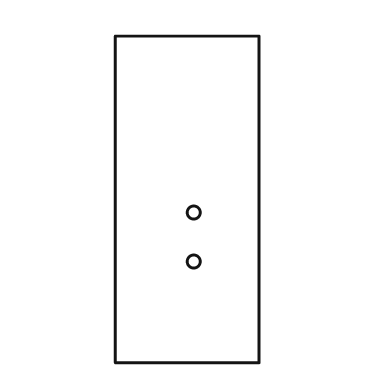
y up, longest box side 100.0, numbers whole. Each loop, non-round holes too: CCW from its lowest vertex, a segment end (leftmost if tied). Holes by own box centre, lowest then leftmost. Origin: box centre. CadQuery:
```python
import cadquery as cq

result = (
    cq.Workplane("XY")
    .moveTo(-22.0, -50.0)
    .lineTo(22.0, -50.0)
    .lineTo(22.0, 50.0)
    .lineTo(-22.0, 50.0)
    .close()
    .moveTo(2.0, -19.0)
    .circle(2.0)
    .moveTo(2.0, -4.0)
    .circle(2.0)
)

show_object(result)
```